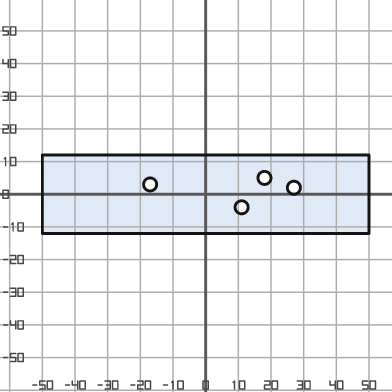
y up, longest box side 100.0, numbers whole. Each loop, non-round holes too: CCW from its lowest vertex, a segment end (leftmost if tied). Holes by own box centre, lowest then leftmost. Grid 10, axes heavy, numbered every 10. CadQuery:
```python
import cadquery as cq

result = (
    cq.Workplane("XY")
    .moveTo(-50.0, -12.0)
    .lineTo(50.0, -12.0)
    .lineTo(50.0, 12.0)
    .lineTo(-50.0, 12.0)
    .close()
    .moveTo(11.0, -4.0)
    .circle(2.0)
    .moveTo(27.0, 2.0)
    .circle(2.0)
    .moveTo(-17.0, 3.0)
    .circle(2.0)
    .moveTo(18.0, 5.0)
    .circle(2.0)
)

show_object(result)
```